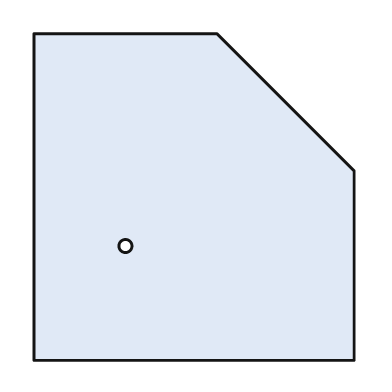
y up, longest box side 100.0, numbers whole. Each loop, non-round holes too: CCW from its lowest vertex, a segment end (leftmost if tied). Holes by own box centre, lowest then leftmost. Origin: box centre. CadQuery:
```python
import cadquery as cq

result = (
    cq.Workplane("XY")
    .moveTo(-49.0, -50.0)
    .lineTo(49.0, -50.0)
    .lineTo(49.0, 8.0)
    .lineTo(7.0, 50.0)
    .lineTo(-49.0, 50.0)
    .close()
    .moveTo(-21.0, -15.0)
    .circle(2.0)
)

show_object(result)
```